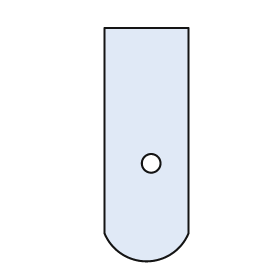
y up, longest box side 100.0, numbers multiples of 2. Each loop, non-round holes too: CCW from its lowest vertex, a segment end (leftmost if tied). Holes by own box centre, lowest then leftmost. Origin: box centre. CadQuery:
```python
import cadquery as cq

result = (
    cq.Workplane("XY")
    .moveTo(-18.0, -38.0)
    .threePointArc((0.0, -50.0), (18.0, -38.0))
    .lineTo(18.0, 50.0)
    .lineTo(-18.0, 50.0)
    .close()
    .moveTo(2.0, -8.0)
    .circle(4.0)
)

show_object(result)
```